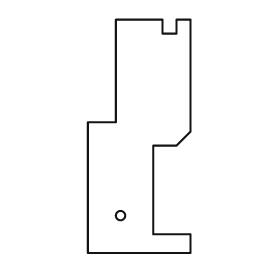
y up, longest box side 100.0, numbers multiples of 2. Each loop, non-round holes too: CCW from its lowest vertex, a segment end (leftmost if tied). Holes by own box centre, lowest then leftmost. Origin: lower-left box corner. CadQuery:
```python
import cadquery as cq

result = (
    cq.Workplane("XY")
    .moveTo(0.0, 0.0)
    .lineTo(44.0, 0.0)
    .lineTo(44.0, 8.0)
    .lineTo(28.0, 8.0)
    .lineTo(28.0, 46.0)
    .lineTo(38.0, 46.0)
    .lineTo(44.0, 52.0)
    .lineTo(44.0, 100.0)
    .lineTo(38.0, 100.0)
    .lineTo(38.0, 94.0)
    .lineTo(32.0, 94.0)
    .lineTo(32.0, 100.0)
    .lineTo(12.0, 100.0)
    .lineTo(12.0, 56.0)
    .lineTo(0.0, 56.0)
    .close()
    .moveTo(14.0, 16.0)
    .circle(2.0)
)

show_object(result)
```